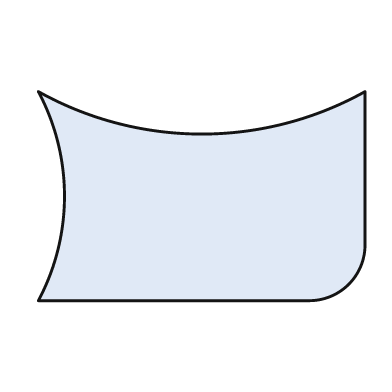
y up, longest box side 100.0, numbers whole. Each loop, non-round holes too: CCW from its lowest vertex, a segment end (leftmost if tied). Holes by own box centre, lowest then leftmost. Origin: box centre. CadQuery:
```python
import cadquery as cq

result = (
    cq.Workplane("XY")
    .moveTo(-50.0, -32.0)
    .lineTo(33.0, -32.0)
    .threePointArc((45.0, -27.0), (50.0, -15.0))
    .lineTo(50.0, 32.0)
    .threePointArc((0.0, 19.0), (-50.0, 32.0))
    .threePointArc((-42.0, 0.0), (-50.0, -32.0))
    .close()
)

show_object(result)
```